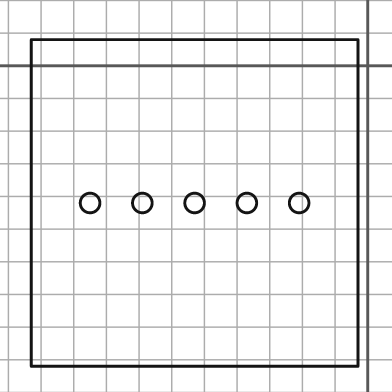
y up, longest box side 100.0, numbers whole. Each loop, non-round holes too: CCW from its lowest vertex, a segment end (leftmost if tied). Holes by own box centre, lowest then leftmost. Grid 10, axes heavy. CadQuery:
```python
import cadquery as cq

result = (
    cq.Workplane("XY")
    .moveTo(-103.0, -92.0)
    .lineTo(-3.0, -92.0)
    .lineTo(-3.0, 8.0)
    .lineTo(-103.0, 8.0)
    .close()
    .moveTo(-85.0, -42.0)
    .circle(3.0)
    .moveTo(-69.0, -42.0)
    .circle(3.0)
    .moveTo(-53.0, -42.0)
    .circle(3.0)
    .moveTo(-37.0, -42.0)
    .circle(3.0)
    .moveTo(-21.0, -42.0)
    .circle(3.0)
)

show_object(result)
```